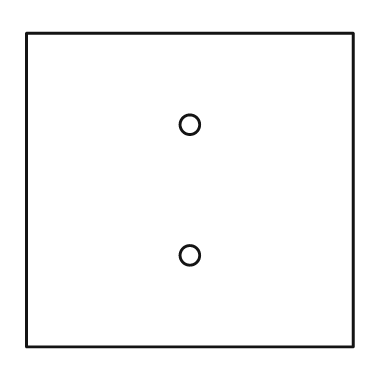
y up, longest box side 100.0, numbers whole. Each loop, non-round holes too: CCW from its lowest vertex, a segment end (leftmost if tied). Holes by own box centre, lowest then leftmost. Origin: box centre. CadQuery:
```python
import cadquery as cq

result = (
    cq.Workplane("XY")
    .moveTo(-50.0, -48.0)
    .lineTo(50.0, -48.0)
    .lineTo(50.0, 48.0)
    .lineTo(-50.0, 48.0)
    .close()
    .moveTo(0.0, -20.0)
    .circle(3.0)
    .moveTo(0.0, 20.0)
    .circle(3.0)
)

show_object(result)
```